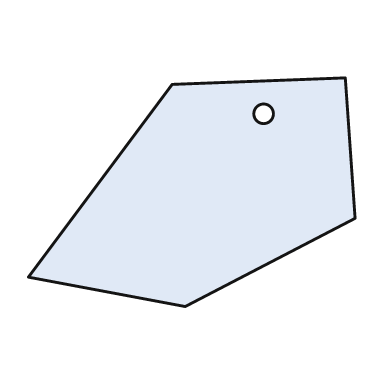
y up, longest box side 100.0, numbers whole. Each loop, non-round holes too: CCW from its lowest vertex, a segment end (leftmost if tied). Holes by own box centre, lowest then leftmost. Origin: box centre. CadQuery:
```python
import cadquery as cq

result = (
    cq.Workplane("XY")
    .moveTo(-2.0, -35.0)
    .lineTo(50.0, -8.0)
    .lineTo(47.0, 35.0)
    .lineTo(-6.0, 33.0)
    .lineTo(-50.0, -26.0)
    .close()
    .moveTo(22.0, 24.0)
    .circle(3.0)
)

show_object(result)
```